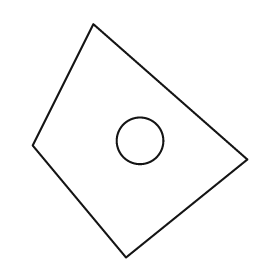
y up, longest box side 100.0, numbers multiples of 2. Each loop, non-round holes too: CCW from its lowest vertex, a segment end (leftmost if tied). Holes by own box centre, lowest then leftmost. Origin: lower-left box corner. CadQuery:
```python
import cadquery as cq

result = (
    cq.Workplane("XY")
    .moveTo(40.0, 0.0)
    .lineTo(92.0, 42.0)
    .lineTo(26.0, 100.0)
    .lineTo(0.0, 48.0)
    .close()
    .moveTo(46.0, 50.0)
    .circle(10.0)
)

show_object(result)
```